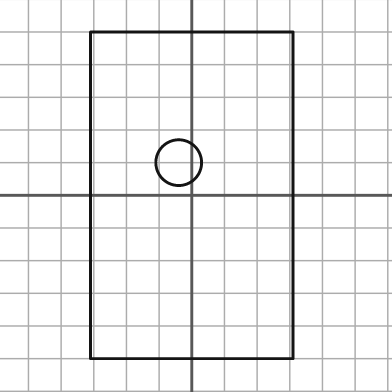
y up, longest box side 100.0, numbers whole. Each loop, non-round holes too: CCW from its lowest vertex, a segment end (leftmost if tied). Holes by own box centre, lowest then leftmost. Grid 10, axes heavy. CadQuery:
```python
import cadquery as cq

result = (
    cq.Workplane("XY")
    .moveTo(-31.0, -50.0)
    .lineTo(31.0, -50.0)
    .lineTo(31.0, 50.0)
    .lineTo(-31.0, 50.0)
    .close()
    .moveTo(-4.0, 10.0)
    .circle(7.0)
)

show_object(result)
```